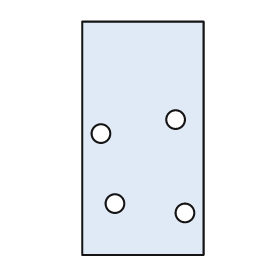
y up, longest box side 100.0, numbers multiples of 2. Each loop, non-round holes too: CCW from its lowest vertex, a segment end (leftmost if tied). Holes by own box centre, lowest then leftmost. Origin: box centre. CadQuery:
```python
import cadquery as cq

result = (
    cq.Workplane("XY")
    .moveTo(-26.0, -50.0)
    .lineTo(26.0, -50.0)
    .lineTo(26.0, 50.0)
    .lineTo(-26.0, 50.0)
    .close()
    .moveTo(18.0, -32.0)
    .circle(4.0)
    .moveTo(-12.0, -28.0)
    .circle(4.0)
    .moveTo(-18.0, 2.0)
    .circle(4.0)
    .moveTo(14.0, 8.0)
    .circle(4.0)
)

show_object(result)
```